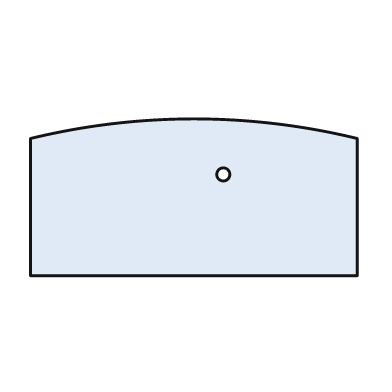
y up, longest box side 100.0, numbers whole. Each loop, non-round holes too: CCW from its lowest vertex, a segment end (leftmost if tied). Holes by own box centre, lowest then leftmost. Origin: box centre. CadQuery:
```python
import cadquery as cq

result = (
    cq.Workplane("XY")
    .moveTo(-50.0, -24.0)
    .lineTo(50.0, -24.0)
    .lineTo(50.0, 18.0)
    .threePointArc((0.0, 24.0), (-50.0, 18.0))
    .close()
    .moveTo(9.0, 7.0)
    .circle(2.0)
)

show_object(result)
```